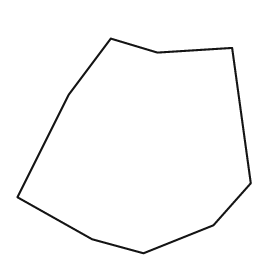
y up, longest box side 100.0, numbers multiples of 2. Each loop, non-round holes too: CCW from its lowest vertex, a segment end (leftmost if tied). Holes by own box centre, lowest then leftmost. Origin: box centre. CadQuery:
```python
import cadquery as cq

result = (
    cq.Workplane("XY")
    .moveTo(4.0, -46.0)
    .lineTo(34.0, -34.0)
    .lineTo(50.0, -16.0)
    .lineTo(42.0, 42.0)
    .lineTo(10.0, 40.0)
    .lineTo(-10.0, 46.0)
    .lineTo(-28.0, 22.0)
    .lineTo(-50.0, -22.0)
    .lineTo(-18.0, -40.0)
    .close()
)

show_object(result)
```